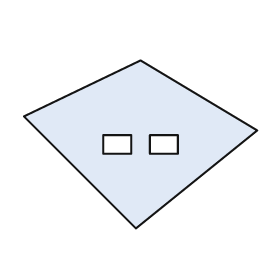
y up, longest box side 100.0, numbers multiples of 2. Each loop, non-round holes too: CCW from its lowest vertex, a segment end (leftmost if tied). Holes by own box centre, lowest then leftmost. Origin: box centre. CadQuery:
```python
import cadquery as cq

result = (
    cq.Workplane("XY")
    .moveTo(-2.0, -36.0)
    .lineTo(50.0, 6.0)
    .lineTo(0.0, 36.0)
    .lineTo(-50.0, 12.0)
    .close()
    .moveTo(-16.0, -4.0)
    .lineTo(-4.0, -4.0)
    .lineTo(-4.0, 4.0)
    .lineTo(-16.0, 4.0)
    .close()
    .moveTo(4.0, -4.0)
    .lineTo(16.0, -4.0)
    .lineTo(16.0, 4.0)
    .lineTo(4.0, 4.0)
    .close()
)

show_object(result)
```